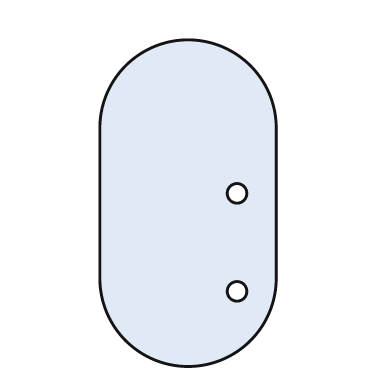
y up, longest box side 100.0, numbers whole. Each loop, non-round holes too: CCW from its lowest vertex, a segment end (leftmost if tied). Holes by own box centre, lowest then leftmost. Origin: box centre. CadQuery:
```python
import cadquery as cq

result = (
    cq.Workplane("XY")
    .moveTo(-27.0, -23.0)
    .threePointArc((0.0, -50.0), (27.0, -23.0))
    .lineTo(27.0, 23.0)
    .threePointArc((0.0, 50.0), (-27.0, 23.0))
    .close()
    .moveTo(15.0, -27.0)
    .circle(3.0)
    .moveTo(15.0, 3.0)
    .circle(3.0)
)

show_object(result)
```